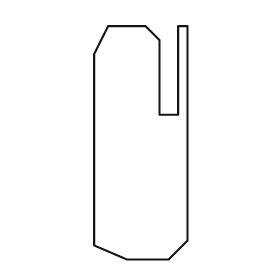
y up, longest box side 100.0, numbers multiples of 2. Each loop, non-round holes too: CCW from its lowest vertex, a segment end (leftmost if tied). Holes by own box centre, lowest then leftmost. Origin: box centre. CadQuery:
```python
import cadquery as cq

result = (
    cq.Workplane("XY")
    .moveTo(-6.0, -50.0)
    .lineTo(12.0, -50.0)
    .lineTo(20.0, -42.0)
    .lineTo(20.0, 50.0)
    .lineTo(16.0, 50.0)
    .lineTo(16.0, 12.0)
    .lineTo(8.0, 12.0)
    .lineTo(8.0, 44.0)
    .lineTo(2.0, 50.0)
    .lineTo(-14.0, 50.0)
    .lineTo(-20.0, 38.0)
    .lineTo(-20.0, -44.0)
    .close()
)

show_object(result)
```